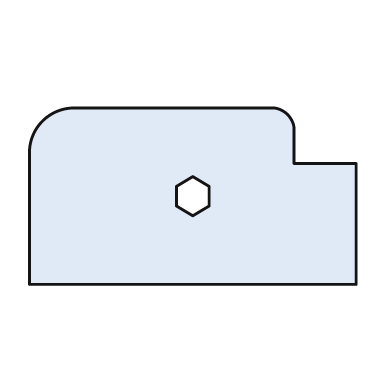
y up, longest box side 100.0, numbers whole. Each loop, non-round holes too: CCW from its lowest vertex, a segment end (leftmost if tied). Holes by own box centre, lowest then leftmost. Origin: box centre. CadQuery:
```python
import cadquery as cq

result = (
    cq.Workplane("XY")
    .moveTo(-50.0, -27.0)
    .lineTo(50.0, -27.0)
    .lineTo(50.0, 10.0)
    .lineTo(31.0, 10.0)
    .lineTo(31.0, 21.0)
    .threePointArc((29.0, 25.0), (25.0, 27.0))
    .lineTo(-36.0, 27.0)
    .threePointArc((-46.0, 23.0), (-50.0, 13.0))
    .close()
    .moveTo(0.0, -6.0)
    .lineTo(5.0, -3.0)
    .lineTo(5.0, 3.0)
    .lineTo(0.0, 6.0)
    .lineTo(-5.0, 3.0)
    .lineTo(-5.0, -3.0)
    .close()
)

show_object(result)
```